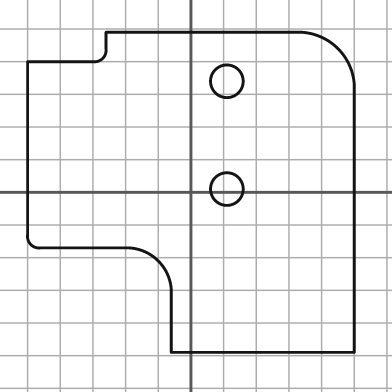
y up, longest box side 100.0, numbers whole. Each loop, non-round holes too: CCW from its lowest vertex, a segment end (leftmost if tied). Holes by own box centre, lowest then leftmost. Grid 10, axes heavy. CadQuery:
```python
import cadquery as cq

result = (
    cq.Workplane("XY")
    .moveTo(-6.0, -49.0)
    .lineTo(50.0, -49.0)
    .lineTo(50.0, 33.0)
    .threePointArc((45.0, 44.0), (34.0, 49.0))
    .lineTo(-26.0, 49.0)
    .lineTo(-26.0, 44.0)
    .threePointArc((-27.0, 41.0), (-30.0, 40.0))
    .lineTo(-50.0, 40.0)
    .lineTo(-50.0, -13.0)
    .threePointArc((-49.0, -16.0), (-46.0, -17.0))
    .lineTo(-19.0, -17.0)
    .threePointArc((-10.0, -21.0), (-6.0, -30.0))
    .close()
    .moveTo(11.0, 1.0)
    .circle(5.0)
    .moveTo(11.0, 34.0)
    .circle(5.0)
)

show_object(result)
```